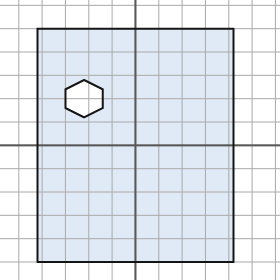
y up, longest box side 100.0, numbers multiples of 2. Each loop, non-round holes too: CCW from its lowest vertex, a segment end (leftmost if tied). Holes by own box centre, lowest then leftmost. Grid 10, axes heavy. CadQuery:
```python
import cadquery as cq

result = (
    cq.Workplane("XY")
    .moveTo(-42.0, -50.0)
    .lineTo(42.0, -50.0)
    .lineTo(42.0, 50.0)
    .lineTo(-42.0, 50.0)
    .close()
    .moveTo(-22.0, 12.0)
    .lineTo(-14.0, 16.0)
    .lineTo(-14.0, 24.0)
    .lineTo(-22.0, 28.0)
    .lineTo(-30.0, 24.0)
    .lineTo(-30.0, 16.0)
    .close()
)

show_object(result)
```